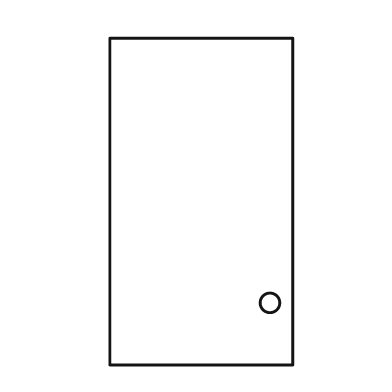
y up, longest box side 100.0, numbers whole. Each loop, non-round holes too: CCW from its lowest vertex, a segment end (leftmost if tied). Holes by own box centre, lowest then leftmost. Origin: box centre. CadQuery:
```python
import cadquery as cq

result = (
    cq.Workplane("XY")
    .moveTo(-28.0, -50.0)
    .lineTo(28.0, -50.0)
    .lineTo(28.0, 50.0)
    .lineTo(-28.0, 50.0)
    .close()
    .moveTo(21.0, -31.0)
    .circle(3.0)
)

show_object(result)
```